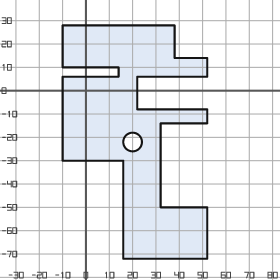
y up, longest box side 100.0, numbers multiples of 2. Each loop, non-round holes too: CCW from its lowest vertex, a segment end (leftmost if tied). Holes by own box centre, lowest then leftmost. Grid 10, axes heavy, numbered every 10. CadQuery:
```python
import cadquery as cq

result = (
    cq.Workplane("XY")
    .moveTo(16.0, -72.0)
    .lineTo(52.0, -72.0)
    .lineTo(52.0, -50.0)
    .lineTo(32.0, -50.0)
    .lineTo(32.0, -14.0)
    .lineTo(52.0, -14.0)
    .lineTo(52.0, -8.0)
    .lineTo(22.0, -8.0)
    .lineTo(22.0, 6.0)
    .lineTo(52.0, 6.0)
    .lineTo(52.0, 14.0)
    .lineTo(38.0, 14.0)
    .lineTo(38.0, 28.0)
    .lineTo(-10.0, 28.0)
    .lineTo(-10.0, 10.0)
    .lineTo(14.0, 10.0)
    .lineTo(14.0, 6.0)
    .lineTo(-10.0, 6.0)
    .lineTo(-10.0, -30.0)
    .lineTo(16.0, -30.0)
    .close()
    .moveTo(20.0, -22.0)
    .circle(4.0)
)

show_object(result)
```